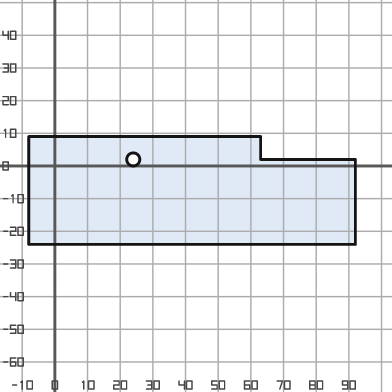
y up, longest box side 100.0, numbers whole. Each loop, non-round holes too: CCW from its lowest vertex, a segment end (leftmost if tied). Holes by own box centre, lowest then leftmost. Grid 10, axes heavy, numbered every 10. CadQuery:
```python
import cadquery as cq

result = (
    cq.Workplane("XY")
    .moveTo(-8.0, -24.0)
    .lineTo(92.0, -24.0)
    .lineTo(92.0, 2.0)
    .lineTo(63.0, 2.0)
    .lineTo(63.0, 9.0)
    .lineTo(-8.0, 9.0)
    .close()
    .moveTo(24.0, 2.0)
    .circle(2.0)
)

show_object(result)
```